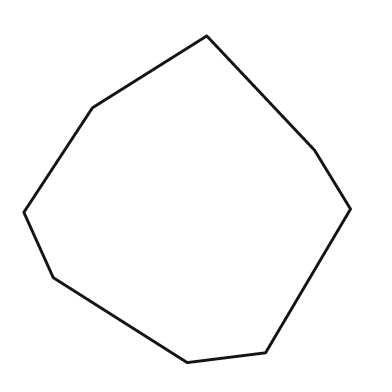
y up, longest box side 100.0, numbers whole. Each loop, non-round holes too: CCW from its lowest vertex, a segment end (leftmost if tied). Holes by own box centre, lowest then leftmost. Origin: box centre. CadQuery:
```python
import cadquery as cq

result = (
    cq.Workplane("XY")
    .moveTo(0.0, -50.0)
    .lineTo(24.0, -47.0)
    .lineTo(50.0, -3.0)
    .lineTo(39.0, 15.0)
    .lineTo(6.0, 50.0)
    .lineTo(-29.0, 28.0)
    .lineTo(-50.0, -4.0)
    .lineTo(-41.0, -24.0)
    .close()
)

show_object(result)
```